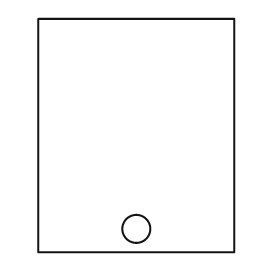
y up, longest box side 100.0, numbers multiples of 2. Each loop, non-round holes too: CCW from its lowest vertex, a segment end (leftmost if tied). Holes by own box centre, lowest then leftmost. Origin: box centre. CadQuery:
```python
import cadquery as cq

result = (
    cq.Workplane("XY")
    .moveTo(-42.0, -50.0)
    .lineTo(42.0, -50.0)
    .lineTo(42.0, 50.0)
    .lineTo(-42.0, 50.0)
    .close()
    .moveTo(0.0, -40.0)
    .circle(6.0)
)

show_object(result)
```